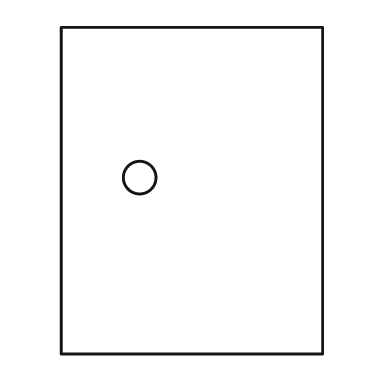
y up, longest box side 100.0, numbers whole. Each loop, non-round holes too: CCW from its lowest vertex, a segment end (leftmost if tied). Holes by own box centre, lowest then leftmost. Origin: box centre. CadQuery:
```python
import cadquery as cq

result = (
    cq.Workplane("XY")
    .moveTo(-40.0, -50.0)
    .lineTo(40.0, -50.0)
    .lineTo(40.0, 50.0)
    .lineTo(-40.0, 50.0)
    .close()
    .moveTo(-16.0, 4.0)
    .circle(5.0)
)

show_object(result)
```